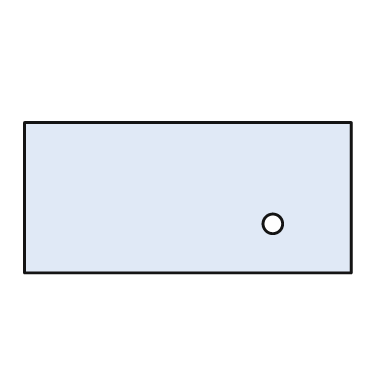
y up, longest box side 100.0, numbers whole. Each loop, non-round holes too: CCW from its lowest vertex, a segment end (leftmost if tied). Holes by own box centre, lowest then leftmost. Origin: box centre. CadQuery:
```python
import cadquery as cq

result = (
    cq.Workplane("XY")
    .moveTo(-50.0, -23.0)
    .lineTo(50.0, -23.0)
    .lineTo(50.0, 23.0)
    .lineTo(-50.0, 23.0)
    .close()
    .moveTo(26.0, -8.0)
    .circle(3.0)
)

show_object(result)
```